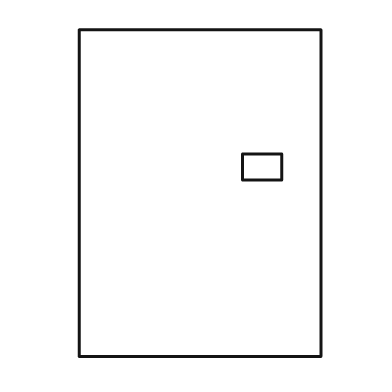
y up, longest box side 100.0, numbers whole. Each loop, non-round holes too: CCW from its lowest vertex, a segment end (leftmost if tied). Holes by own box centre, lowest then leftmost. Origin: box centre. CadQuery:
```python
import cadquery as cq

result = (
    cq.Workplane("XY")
    .moveTo(-37.0, -50.0)
    .lineTo(37.0, -50.0)
    .lineTo(37.0, 50.0)
    .lineTo(-37.0, 50.0)
    .close()
    .moveTo(13.0, 4.0)
    .lineTo(25.0, 4.0)
    .lineTo(25.0, 12.0)
    .lineTo(13.0, 12.0)
    .close()
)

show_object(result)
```